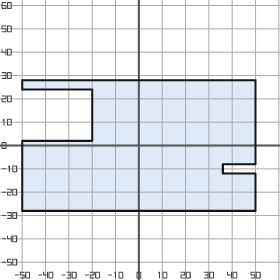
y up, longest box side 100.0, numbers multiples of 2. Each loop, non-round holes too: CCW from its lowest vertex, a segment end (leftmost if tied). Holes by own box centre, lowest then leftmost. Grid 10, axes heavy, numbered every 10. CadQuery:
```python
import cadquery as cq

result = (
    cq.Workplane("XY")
    .moveTo(-50.0, -28.0)
    .lineTo(50.0, -28.0)
    .lineTo(50.0, -12.0)
    .lineTo(36.0, -12.0)
    .lineTo(36.0, -8.0)
    .lineTo(50.0, -8.0)
    .lineTo(50.0, 28.0)
    .lineTo(-50.0, 28.0)
    .lineTo(-50.0, 24.0)
    .lineTo(-20.0, 24.0)
    .lineTo(-20.0, 2.0)
    .lineTo(-50.0, 2.0)
    .close()
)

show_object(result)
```